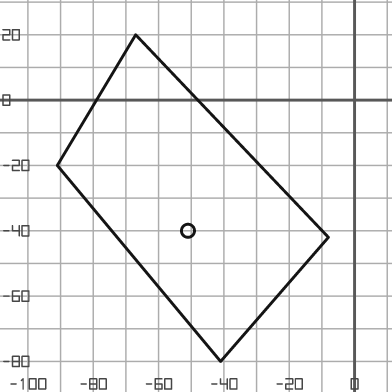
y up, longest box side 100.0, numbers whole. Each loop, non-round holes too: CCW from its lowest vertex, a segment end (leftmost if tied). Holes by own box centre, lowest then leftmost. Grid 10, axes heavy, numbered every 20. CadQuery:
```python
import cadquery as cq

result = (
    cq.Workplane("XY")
    .moveTo(-41.0, -80.0)
    .lineTo(-8.0, -42.0)
    .lineTo(-67.0, 20.0)
    .lineTo(-91.0, -20.0)
    .close()
    .moveTo(-51.0, -40.0)
    .circle(2.0)
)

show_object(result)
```